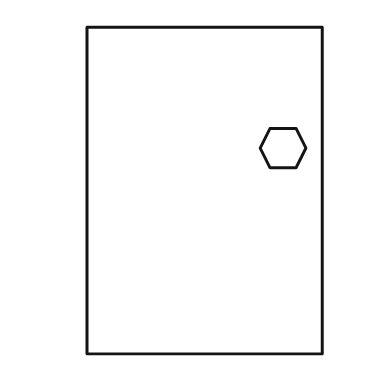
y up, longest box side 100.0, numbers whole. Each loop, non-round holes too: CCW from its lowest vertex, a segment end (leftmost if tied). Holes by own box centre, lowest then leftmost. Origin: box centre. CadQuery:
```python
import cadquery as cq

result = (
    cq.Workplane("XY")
    .moveTo(-36.0, -50.0)
    .lineTo(36.0, -50.0)
    .lineTo(36.0, 50.0)
    .lineTo(-36.0, 50.0)
    .close()
    .moveTo(20.0, 7.0)
    .lineTo(28.0, 7.0)
    .lineTo(31.0, 13.0)
    .lineTo(28.0, 19.0)
    .lineTo(20.0, 19.0)
    .lineTo(17.0, 13.0)
    .close()
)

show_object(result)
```